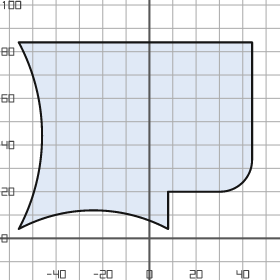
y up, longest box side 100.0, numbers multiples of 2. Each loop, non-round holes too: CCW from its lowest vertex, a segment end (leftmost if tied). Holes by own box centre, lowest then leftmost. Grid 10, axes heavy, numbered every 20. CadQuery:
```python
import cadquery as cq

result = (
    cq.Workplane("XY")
    .moveTo(-56.0, 4.0)
    .threePointArc((-24.0, 12.0), (8.0, 4.0))
    .lineTo(8.0, 20.0)
    .lineTo(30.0, 20.0)
    .threePointArc((40.0, 24.0), (44.0, 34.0))
    .lineTo(44.0, 84.0)
    .lineTo(-56.0, 84.0)
    .threePointArc((-46.0, 44.0), (-56.0, 4.0))
    .close()
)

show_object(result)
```